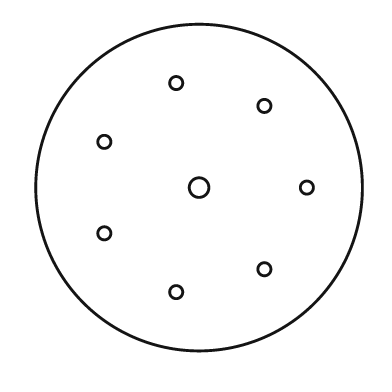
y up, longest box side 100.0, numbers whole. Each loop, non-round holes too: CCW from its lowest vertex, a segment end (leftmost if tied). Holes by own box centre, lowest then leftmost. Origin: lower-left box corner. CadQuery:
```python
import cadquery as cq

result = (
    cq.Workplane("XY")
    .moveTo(50.0, 50.0)
    .circle(50.0)
    .moveTo(43.0, 18.0)
    .circle(2.0)
    .moveTo(70.0, 25.0)
    .circle(2.0)
    .moveTo(21.0, 36.0)
    .circle(2.0)
    .moveTo(50.0, 50.0)
    .circle(3.0)
    .moveTo(83.0, 50.0)
    .circle(2.0)
    .moveTo(21.0, 64.0)
    .circle(2.0)
    .moveTo(70.0, 75.0)
    .circle(2.0)
    .moveTo(43.0, 82.0)
    .circle(2.0)
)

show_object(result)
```